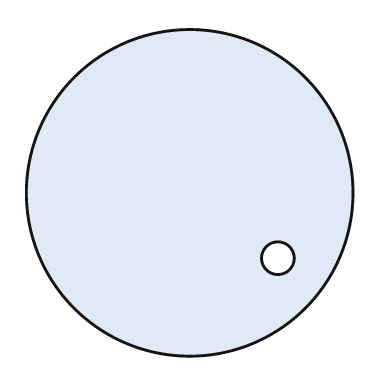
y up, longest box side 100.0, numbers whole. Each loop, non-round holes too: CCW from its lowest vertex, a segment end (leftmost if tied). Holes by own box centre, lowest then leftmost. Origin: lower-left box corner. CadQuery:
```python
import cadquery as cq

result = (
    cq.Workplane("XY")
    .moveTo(50.0, 50.0)
    .circle(50.0)
    .moveTo(77.0, 30.0)
    .circle(5.0)
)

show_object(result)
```